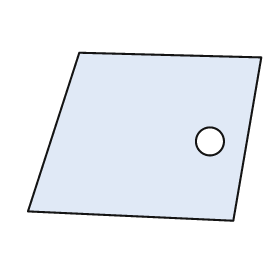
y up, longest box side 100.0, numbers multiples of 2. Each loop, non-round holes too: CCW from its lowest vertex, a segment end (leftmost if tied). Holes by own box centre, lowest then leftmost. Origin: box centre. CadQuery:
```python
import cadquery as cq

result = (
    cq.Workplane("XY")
    .moveTo(38.0, -36.0)
    .lineTo(50.0, 34.0)
    .lineTo(-28.0, 36.0)
    .lineTo(-50.0, -32.0)
    .close()
    .moveTo(28.0, -2.0)
    .circle(6.0)
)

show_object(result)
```